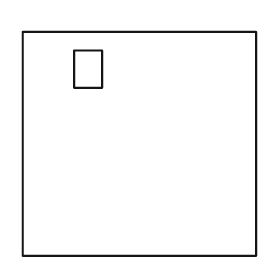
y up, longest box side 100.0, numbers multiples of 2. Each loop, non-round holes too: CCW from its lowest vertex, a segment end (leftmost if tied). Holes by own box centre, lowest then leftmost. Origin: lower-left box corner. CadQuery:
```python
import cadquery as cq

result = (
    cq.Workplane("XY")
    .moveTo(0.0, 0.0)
    .lineTo(100.0, 0.0)
    .lineTo(100.0, 96.0)
    .lineTo(0.0, 96.0)
    .close()
    .moveTo(22.0, 72.0)
    .lineTo(34.0, 72.0)
    .lineTo(34.0, 88.0)
    .lineTo(22.0, 88.0)
    .close()
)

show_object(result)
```